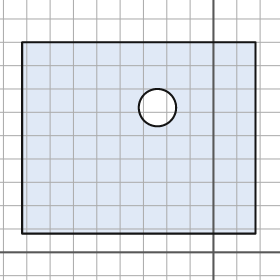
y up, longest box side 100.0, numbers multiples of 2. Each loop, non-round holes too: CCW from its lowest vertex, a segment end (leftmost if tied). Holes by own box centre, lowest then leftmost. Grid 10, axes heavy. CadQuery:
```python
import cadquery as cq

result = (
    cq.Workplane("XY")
    .moveTo(-82.0, 8.0)
    .lineTo(18.0, 8.0)
    .lineTo(18.0, 90.0)
    .lineTo(-82.0, 90.0)
    .close()
    .moveTo(-24.0, 62.0)
    .circle(8.0)
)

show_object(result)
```